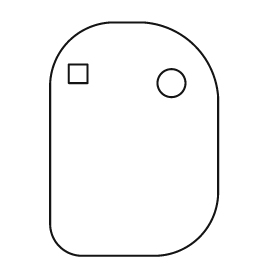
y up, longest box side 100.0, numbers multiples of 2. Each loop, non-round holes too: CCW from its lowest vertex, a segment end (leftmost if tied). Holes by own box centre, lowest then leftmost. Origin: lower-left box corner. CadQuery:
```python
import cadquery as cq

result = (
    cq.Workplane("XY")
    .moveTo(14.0, 0.0)
    .lineTo(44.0, 0.0)
    .threePointArc((64.0, 8.0), (72.0, 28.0))
    .lineTo(72.0, 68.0)
    .threePointArc((62.0, 90.0), (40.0, 100.0))
    .lineTo(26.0, 100.0)
    .threePointArc((8.0, 92.0), (0.0, 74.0))
    .lineTo(0.0, 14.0)
    .threePointArc((4.0, 4.0), (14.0, 0.0))
    .close()
    .moveTo(52.0, 74.0)
    .circle(6.0)
    .moveTo(8.0, 74.0)
    .lineTo(16.0, 74.0)
    .lineTo(16.0, 82.0)
    .lineTo(8.0, 82.0)
    .close()
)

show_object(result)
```